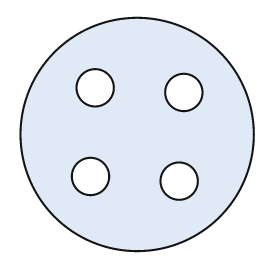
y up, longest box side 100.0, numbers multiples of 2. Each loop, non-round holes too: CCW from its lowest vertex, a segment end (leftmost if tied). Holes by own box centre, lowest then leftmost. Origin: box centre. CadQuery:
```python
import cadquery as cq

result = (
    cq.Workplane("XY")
    .moveTo(0.0, 0.0)
    .circle(50.0)
    .moveTo(18.0, -20.0)
    .circle(8.0)
    .moveTo(-20.0, -18.0)
    .circle(8.0)
    .moveTo(20.0, 18.0)
    .circle(8.0)
    .moveTo(-18.0, 20.0)
    .circle(8.0)
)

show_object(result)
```